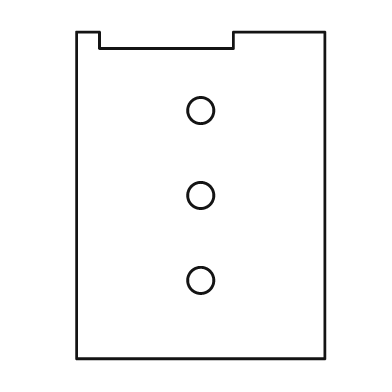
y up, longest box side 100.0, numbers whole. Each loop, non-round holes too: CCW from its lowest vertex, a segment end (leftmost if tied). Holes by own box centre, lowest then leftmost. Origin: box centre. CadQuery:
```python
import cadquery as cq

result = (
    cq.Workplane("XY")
    .moveTo(-38.0, -50.0)
    .lineTo(38.0, -50.0)
    .lineTo(38.0, 50.0)
    .lineTo(10.0, 50.0)
    .lineTo(10.0, 45.0)
    .lineTo(-31.0, 45.0)
    .lineTo(-31.0, 50.0)
    .lineTo(-38.0, 50.0)
    .close()
    .moveTo(0.0, -26.0)
    .circle(4.0)
    .moveTo(0.0, 0.0)
    .circle(4.0)
    .moveTo(0.0, 26.0)
    .circle(4.0)
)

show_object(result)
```